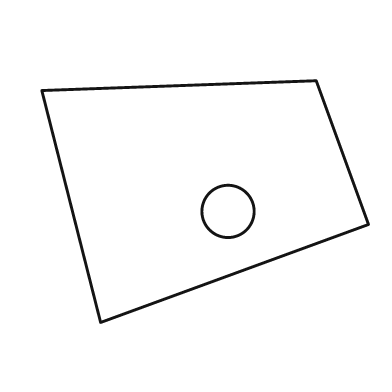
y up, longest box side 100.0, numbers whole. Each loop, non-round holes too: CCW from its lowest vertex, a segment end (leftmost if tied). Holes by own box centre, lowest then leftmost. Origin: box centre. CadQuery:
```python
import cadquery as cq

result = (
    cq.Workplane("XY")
    .moveTo(-32.0, -37.0)
    .lineTo(50.0, -7.0)
    .lineTo(34.0, 37.0)
    .lineTo(-50.0, 34.0)
    .close()
    .moveTo(7.0, -3.0)
    .circle(8.0)
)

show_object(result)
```